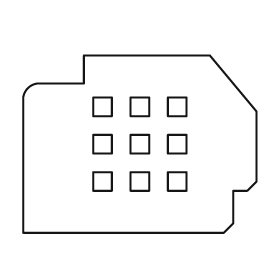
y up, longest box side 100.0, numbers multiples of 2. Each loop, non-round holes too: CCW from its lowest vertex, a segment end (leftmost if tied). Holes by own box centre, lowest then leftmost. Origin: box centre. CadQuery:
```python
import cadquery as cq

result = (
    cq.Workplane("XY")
    .moveTo(-50.0, -38.0)
    .lineTo(36.0, -38.0)
    .lineTo(40.0, -34.0)
    .lineTo(40.0, -20.0)
    .lineTo(46.0, -20.0)
    .lineTo(50.0, -16.0)
    .lineTo(50.0, 14.0)
    .lineTo(30.0, 38.0)
    .lineTo(-24.0, 38.0)
    .lineTo(-24.0, 26.0)
    .lineTo(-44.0, 26.0)
    .threePointArc((-48.0, 24.0), (-50.0, 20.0))
    .close()
    .moveTo(-20.0, -20.0)
    .lineTo(-12.0, -20.0)
    .lineTo(-12.0, -12.0)
    .lineTo(-20.0, -12.0)
    .close()
    .moveTo(-4.0, -20.0)
    .lineTo(4.0, -20.0)
    .lineTo(4.0, -12.0)
    .lineTo(-4.0, -12.0)
    .close()
    .moveTo(12.0, -20.0)
    .lineTo(20.0, -20.0)
    .lineTo(20.0, -12.0)
    .lineTo(12.0, -12.0)
    .close()
    .moveTo(-20.0, -4.0)
    .lineTo(-12.0, -4.0)
    .lineTo(-12.0, 4.0)
    .lineTo(-20.0, 4.0)
    .close()
    .moveTo(-4.0, -4.0)
    .lineTo(4.0, -4.0)
    .lineTo(4.0, 4.0)
    .lineTo(-4.0, 4.0)
    .close()
    .moveTo(12.0, -4.0)
    .lineTo(20.0, -4.0)
    .lineTo(20.0, 4.0)
    .lineTo(12.0, 4.0)
    .close()
    .moveTo(-20.0, 12.0)
    .lineTo(-12.0, 12.0)
    .lineTo(-12.0, 20.0)
    .lineTo(-20.0, 20.0)
    .close()
    .moveTo(-4.0, 12.0)
    .lineTo(4.0, 12.0)
    .lineTo(4.0, 20.0)
    .lineTo(-4.0, 20.0)
    .close()
    .moveTo(12.0, 12.0)
    .lineTo(20.0, 12.0)
    .lineTo(20.0, 20.0)
    .lineTo(12.0, 20.0)
    .close()
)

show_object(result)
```